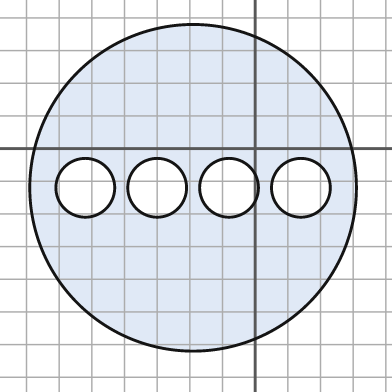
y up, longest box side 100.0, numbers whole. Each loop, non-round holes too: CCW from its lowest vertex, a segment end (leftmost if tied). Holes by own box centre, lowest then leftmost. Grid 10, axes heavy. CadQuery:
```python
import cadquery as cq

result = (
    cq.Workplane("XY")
    .moveTo(-19.0, -12.0)
    .circle(50.0)
    .moveTo(-52.0, -12.0)
    .circle(9.0)
    .moveTo(-30.0, -12.0)
    .circle(9.0)
    .moveTo(-8.0, -12.0)
    .circle(9.0)
    .moveTo(14.0, -12.0)
    .circle(9.0)
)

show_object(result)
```